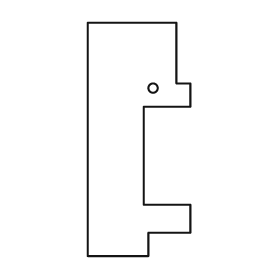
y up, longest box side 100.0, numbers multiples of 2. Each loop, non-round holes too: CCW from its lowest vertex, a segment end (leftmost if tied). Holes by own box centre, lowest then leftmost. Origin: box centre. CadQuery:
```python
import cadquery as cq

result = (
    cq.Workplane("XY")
    .moveTo(-22.0, -50.0)
    .lineTo(4.0, -50.0)
    .lineTo(4.0, -40.0)
    .lineTo(22.0, -40.0)
    .lineTo(22.0, -28.0)
    .lineTo(2.0, -28.0)
    .lineTo(2.0, 14.0)
    .lineTo(22.0, 14.0)
    .lineTo(22.0, 24.0)
    .lineTo(16.0, 24.0)
    .lineTo(16.0, 50.0)
    .lineTo(-22.0, 50.0)
    .close()
    .moveTo(6.0, 22.0)
    .circle(2.0)
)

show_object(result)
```